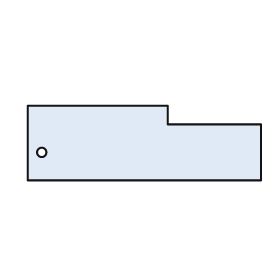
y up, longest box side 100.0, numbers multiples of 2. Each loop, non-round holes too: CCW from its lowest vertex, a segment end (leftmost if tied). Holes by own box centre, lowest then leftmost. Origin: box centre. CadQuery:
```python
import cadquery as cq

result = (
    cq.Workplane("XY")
    .moveTo(-50.0, -16.0)
    .lineTo(50.0, -16.0)
    .lineTo(50.0, 8.0)
    .lineTo(10.0, 8.0)
    .lineTo(10.0, 16.0)
    .lineTo(-50.0, 16.0)
    .close()
    .moveTo(-44.0, -4.0)
    .circle(2.0)
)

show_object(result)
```